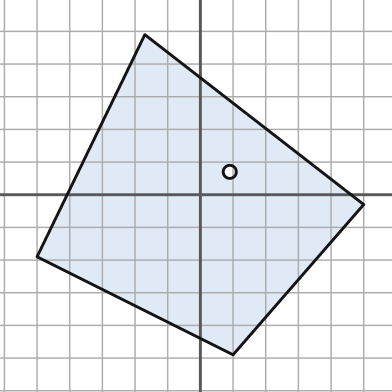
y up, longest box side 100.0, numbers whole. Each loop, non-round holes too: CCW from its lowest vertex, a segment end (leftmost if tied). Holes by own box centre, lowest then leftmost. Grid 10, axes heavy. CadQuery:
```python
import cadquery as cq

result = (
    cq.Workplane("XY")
    .moveTo(10.0, -49.0)
    .lineTo(50.0, -3.0)
    .lineTo(-17.0, 49.0)
    .lineTo(-50.0, -19.0)
    .close()
    .moveTo(9.0, 7.0)
    .circle(2.0)
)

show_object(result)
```